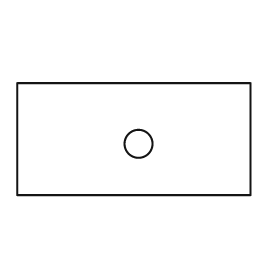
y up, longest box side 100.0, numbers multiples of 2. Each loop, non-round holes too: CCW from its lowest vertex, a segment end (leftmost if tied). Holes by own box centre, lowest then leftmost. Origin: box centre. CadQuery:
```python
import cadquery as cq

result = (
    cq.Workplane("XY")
    .moveTo(-50.0, -24.0)
    .lineTo(50.0, -24.0)
    .lineTo(50.0, 24.0)
    .lineTo(-50.0, 24.0)
    .close()
    .moveTo(2.0, -2.0)
    .circle(6.0)
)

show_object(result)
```